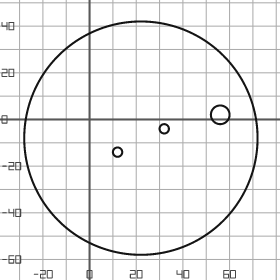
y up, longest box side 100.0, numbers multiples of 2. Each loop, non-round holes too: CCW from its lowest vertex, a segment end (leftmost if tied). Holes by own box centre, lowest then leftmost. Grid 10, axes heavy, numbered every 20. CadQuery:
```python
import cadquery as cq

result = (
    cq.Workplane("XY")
    .moveTo(22.0, -8.0)
    .circle(50.0)
    .moveTo(12.0, -14.0)
    .circle(2.0)
    .moveTo(32.0, -4.0)
    .circle(2.0)
    .moveTo(56.0, 2.0)
    .circle(4.0)
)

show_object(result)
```